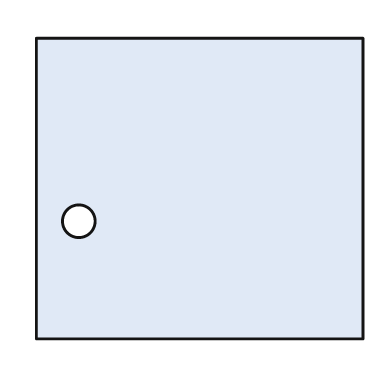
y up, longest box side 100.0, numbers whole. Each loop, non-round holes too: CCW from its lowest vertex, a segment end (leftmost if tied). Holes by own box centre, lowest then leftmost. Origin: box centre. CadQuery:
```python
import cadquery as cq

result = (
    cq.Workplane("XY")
    .moveTo(-50.0, -46.0)
    .lineTo(50.0, -46.0)
    .lineTo(50.0, 46.0)
    .lineTo(-50.0, 46.0)
    .close()
    .moveTo(-37.0, -10.0)
    .circle(5.0)
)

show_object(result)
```